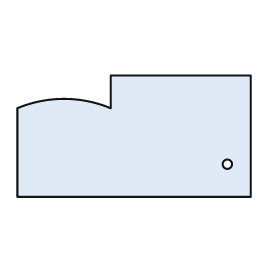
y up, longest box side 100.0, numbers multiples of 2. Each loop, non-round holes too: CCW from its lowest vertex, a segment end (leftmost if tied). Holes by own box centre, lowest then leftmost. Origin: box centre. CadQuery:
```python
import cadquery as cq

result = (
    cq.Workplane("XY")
    .moveTo(-50.0, -26.0)
    .lineTo(50.0, -26.0)
    .lineTo(50.0, 26.0)
    .lineTo(-10.0, 26.0)
    .lineTo(-10.0, 12.0)
    .threePointArc((-30.0, 16.0), (-50.0, 12.0))
    .close()
    .moveTo(40.0, -12.0)
    .circle(2.0)
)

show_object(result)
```